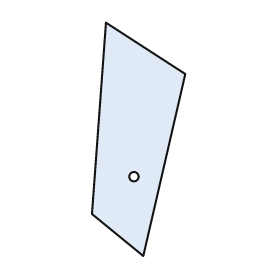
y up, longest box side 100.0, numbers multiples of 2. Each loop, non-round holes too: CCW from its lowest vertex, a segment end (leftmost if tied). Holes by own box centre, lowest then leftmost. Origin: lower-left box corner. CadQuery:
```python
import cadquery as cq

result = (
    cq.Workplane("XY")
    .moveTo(22.0, 0.0)
    .lineTo(40.0, 78.0)
    .lineTo(6.0, 100.0)
    .lineTo(0.0, 18.0)
    .close()
    .moveTo(18.0, 34.0)
    .circle(2.0)
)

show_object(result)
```